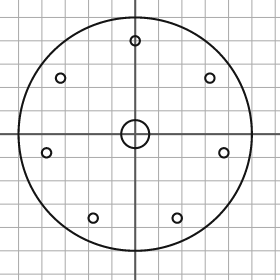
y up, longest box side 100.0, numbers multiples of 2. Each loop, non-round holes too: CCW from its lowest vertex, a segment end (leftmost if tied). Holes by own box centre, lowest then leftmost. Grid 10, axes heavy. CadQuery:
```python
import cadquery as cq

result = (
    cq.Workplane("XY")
    .moveTo(0.0, 0.0)
    .circle(50.0)
    .moveTo(-18.0, -36.0)
    .circle(2.0)
    .moveTo(18.0, -36.0)
    .circle(2.0)
    .moveTo(-38.0, -8.0)
    .circle(2.0)
    .moveTo(38.0, -8.0)
    .circle(2.0)
    .moveTo(0.0, 0.0)
    .circle(6.0)
    .moveTo(-32.0, 24.0)
    .circle(2.0)
    .moveTo(32.0, 24.0)
    .circle(2.0)
    .moveTo(0.0, 40.0)
    .circle(2.0)
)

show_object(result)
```